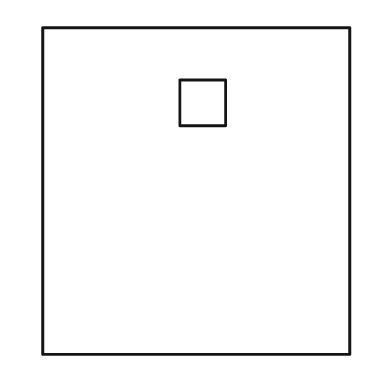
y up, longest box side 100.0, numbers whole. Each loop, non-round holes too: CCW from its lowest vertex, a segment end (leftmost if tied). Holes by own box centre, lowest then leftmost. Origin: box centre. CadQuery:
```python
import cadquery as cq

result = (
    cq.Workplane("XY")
    .moveTo(-47.0, -50.0)
    .lineTo(47.0, -50.0)
    .lineTo(47.0, 50.0)
    .lineTo(-47.0, 50.0)
    .close()
    .moveTo(-5.0, 20.0)
    .lineTo(9.0, 20.0)
    .lineTo(9.0, 34.0)
    .lineTo(-5.0, 34.0)
    .close()
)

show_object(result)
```